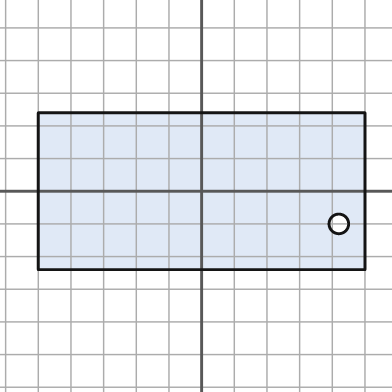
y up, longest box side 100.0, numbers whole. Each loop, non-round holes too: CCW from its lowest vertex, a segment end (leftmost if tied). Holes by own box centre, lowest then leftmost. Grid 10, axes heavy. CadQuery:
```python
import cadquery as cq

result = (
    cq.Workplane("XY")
    .moveTo(-50.0, -24.0)
    .lineTo(50.0, -24.0)
    .lineTo(50.0, 24.0)
    .lineTo(-50.0, 24.0)
    .close()
    .moveTo(42.0, -10.0)
    .circle(3.0)
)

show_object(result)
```